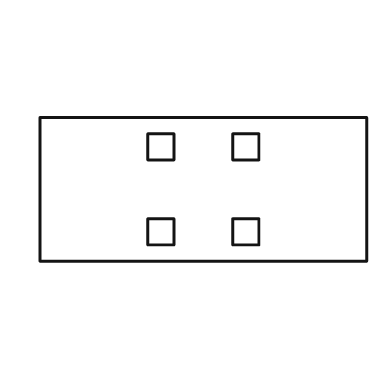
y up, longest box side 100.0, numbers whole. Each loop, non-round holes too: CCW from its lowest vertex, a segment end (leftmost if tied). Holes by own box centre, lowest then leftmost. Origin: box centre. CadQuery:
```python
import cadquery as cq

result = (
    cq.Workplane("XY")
    .moveTo(-50.0, -22.0)
    .lineTo(50.0, -22.0)
    .lineTo(50.0, 22.0)
    .lineTo(-50.0, 22.0)
    .close()
    .moveTo(-17.0, -17.0)
    .lineTo(-9.0, -17.0)
    .lineTo(-9.0, -9.0)
    .lineTo(-17.0, -9.0)
    .close()
    .moveTo(9.0, -17.0)
    .lineTo(17.0, -17.0)
    .lineTo(17.0, -9.0)
    .lineTo(9.0, -9.0)
    .close()
    .moveTo(-17.0, 9.0)
    .lineTo(-9.0, 9.0)
    .lineTo(-9.0, 17.0)
    .lineTo(-17.0, 17.0)
    .close()
    .moveTo(9.0, 9.0)
    .lineTo(17.0, 9.0)
    .lineTo(17.0, 17.0)
    .lineTo(9.0, 17.0)
    .close()
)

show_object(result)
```